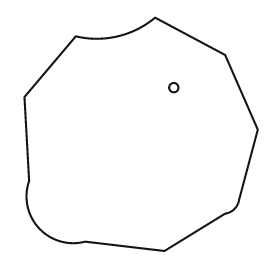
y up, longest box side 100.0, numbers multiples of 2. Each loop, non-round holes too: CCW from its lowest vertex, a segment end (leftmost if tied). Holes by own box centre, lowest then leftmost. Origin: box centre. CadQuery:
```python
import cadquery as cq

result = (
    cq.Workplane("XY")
    .moveTo(10.0, -50.0)
    .lineTo(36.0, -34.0)
    .threePointArc((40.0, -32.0), (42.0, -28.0))
    .lineTo(50.0, 2.0)
    .lineTo(36.0, 34.0)
    .lineTo(6.0, 50.0)
    .threePointArc((-10.0, 42.0), (-28.0, 42.0))
    .lineTo(-50.0, 16.0)
    .lineTo(-48.0, -20.0)
    .threePointArc((-44.0, -40.0), (-24.0, -46.0))
    .close()
    .moveTo(14.0, 20.0)
    .circle(2.0)
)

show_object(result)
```